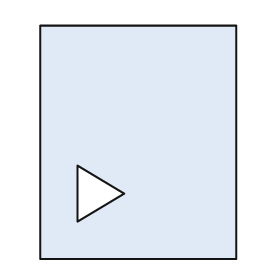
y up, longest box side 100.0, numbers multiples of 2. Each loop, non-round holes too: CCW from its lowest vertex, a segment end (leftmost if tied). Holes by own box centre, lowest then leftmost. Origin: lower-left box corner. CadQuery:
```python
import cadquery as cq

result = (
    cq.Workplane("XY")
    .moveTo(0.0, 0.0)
    .lineTo(84.0, 0.0)
    .lineTo(84.0, 100.0)
    .lineTo(0.0, 100.0)
    .close()
    .moveTo(16.0, 16.0)
    .lineTo(36.0, 28.0)
    .lineTo(16.0, 40.0)
    .close()
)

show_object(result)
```